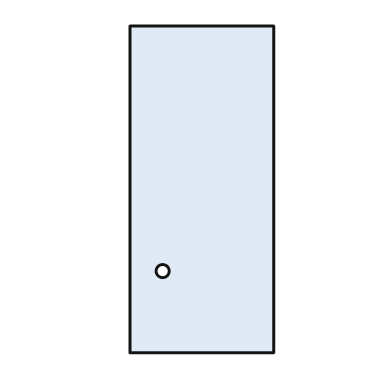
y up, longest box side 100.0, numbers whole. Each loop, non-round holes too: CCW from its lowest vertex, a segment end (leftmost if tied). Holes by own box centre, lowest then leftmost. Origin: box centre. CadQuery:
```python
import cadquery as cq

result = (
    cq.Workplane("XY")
    .moveTo(-22.0, -50.0)
    .lineTo(22.0, -50.0)
    .lineTo(22.0, 50.0)
    .lineTo(-22.0, 50.0)
    .close()
    .moveTo(-12.0, -25.0)
    .circle(2.0)
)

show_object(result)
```